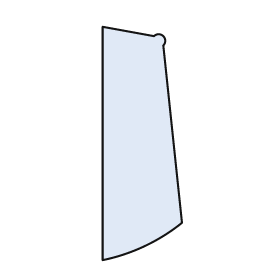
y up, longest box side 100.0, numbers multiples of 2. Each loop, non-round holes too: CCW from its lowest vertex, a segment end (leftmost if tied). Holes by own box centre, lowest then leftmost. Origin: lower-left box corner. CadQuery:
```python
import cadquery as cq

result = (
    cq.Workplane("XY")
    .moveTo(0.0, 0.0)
    .threePointArc((18.0, 6.0), (34.0, 16.0))
    .lineTo(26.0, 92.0)
    .threePointArc((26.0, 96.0), (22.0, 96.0))
    .lineTo(0.0, 100.0)
    .close()
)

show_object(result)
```